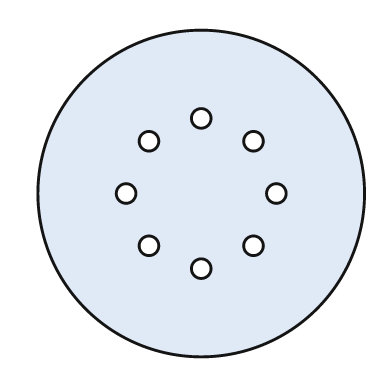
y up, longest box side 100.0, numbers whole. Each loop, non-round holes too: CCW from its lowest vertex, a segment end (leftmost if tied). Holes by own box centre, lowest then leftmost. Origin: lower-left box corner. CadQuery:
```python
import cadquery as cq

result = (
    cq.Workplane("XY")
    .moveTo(50.0, 50.0)
    .circle(50.0)
    .moveTo(50.0, 27.0)
    .circle(3.0)
    .moveTo(34.0, 34.0)
    .circle(3.0)
    .moveTo(66.0, 34.0)
    .circle(3.0)
    .moveTo(27.0, 50.0)
    .circle(3.0)
    .moveTo(73.0, 50.0)
    .circle(3.0)
    .moveTo(34.0, 66.0)
    .circle(3.0)
    .moveTo(66.0, 66.0)
    .circle(3.0)
    .moveTo(50.0, 73.0)
    .circle(3.0)
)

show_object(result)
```